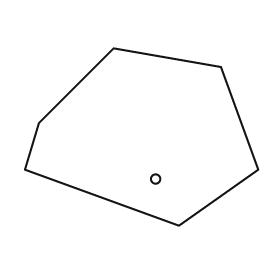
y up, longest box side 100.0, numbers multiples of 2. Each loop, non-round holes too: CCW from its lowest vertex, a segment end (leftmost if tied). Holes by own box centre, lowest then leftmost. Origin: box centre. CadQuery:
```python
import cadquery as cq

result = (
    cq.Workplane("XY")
    .moveTo(16.0, -38.0)
    .lineTo(50.0, -14.0)
    .lineTo(34.0, 30.0)
    .lineTo(-12.0, 38.0)
    .lineTo(-44.0, 6.0)
    .lineTo(-50.0, -14.0)
    .close()
    .moveTo(6.0, -18.0)
    .circle(2.0)
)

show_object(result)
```